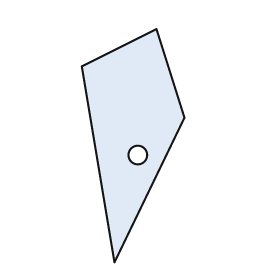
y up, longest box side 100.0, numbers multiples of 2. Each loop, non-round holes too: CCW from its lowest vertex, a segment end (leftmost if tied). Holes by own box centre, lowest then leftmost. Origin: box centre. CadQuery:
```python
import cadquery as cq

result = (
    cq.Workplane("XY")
    .moveTo(-8.0, -50.0)
    .lineTo(22.0, 12.0)
    .lineTo(10.0, 50.0)
    .lineTo(-22.0, 34.0)
    .close()
    .moveTo(2.0, -4.0)
    .circle(4.0)
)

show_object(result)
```